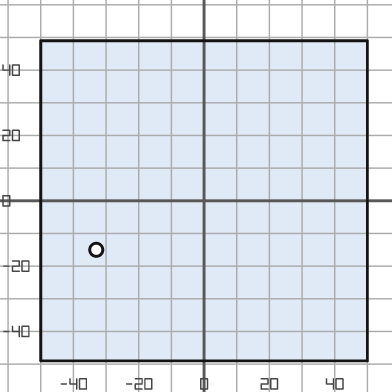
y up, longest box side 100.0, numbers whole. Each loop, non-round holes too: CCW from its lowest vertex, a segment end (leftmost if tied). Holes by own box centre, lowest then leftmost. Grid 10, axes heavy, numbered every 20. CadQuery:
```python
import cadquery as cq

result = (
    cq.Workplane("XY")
    .moveTo(-50.0, -49.0)
    .lineTo(50.0, -49.0)
    .lineTo(50.0, 49.0)
    .lineTo(-50.0, 49.0)
    .close()
    .moveTo(-33.0, -15.0)
    .circle(2.0)
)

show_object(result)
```